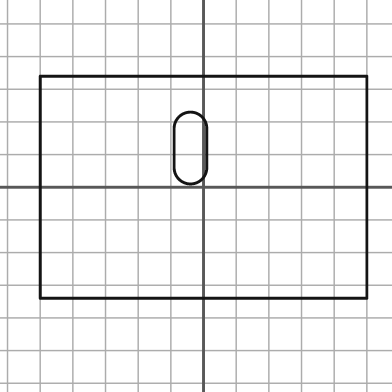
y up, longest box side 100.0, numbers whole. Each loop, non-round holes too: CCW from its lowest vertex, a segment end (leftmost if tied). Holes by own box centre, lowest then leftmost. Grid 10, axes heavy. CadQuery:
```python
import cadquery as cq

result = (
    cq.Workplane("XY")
    .moveTo(-50.0, -34.0)
    .lineTo(50.0, -34.0)
    .lineTo(50.0, 34.0)
    .lineTo(-50.0, 34.0)
    .close()
    .moveTo(-9.0, 6.0)
    .threePointArc((-4.0, 1.0), (1.0, 6.0))
    .lineTo(1.0, 18.0)
    .threePointArc((-4.0, 23.0), (-9.0, 18.0))
    .close()
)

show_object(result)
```